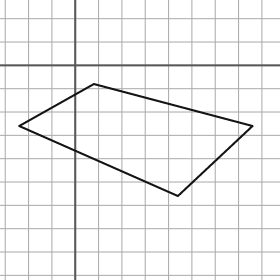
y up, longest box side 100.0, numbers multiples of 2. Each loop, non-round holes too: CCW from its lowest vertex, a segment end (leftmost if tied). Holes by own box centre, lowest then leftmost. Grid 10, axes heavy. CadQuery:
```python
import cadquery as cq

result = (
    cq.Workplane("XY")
    .moveTo(44.0, -56.0)
    .lineTo(76.0, -26.0)
    .lineTo(8.0, -8.0)
    .lineTo(-24.0, -26.0)
    .close()
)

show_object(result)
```